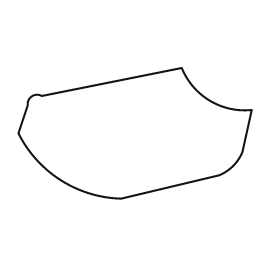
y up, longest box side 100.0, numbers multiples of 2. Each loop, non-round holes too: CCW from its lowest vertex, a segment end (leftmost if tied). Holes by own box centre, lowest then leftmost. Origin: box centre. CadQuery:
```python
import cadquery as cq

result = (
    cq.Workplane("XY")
    .moveTo(-6.0, -28.0)
    .lineTo(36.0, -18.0)
    .threePointArc((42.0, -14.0), (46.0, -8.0))
    .lineTo(50.0, 10.0)
    .threePointArc((32.0, 14.0), (20.0, 28.0))
    .lineTo(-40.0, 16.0)
    .threePointArc((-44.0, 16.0), (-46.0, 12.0))
    .lineTo(-50.0, 0.0)
    .threePointArc((-32.0, -20.0), (-6.0, -28.0))
    .close()
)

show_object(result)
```